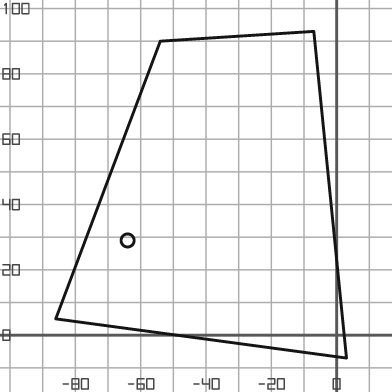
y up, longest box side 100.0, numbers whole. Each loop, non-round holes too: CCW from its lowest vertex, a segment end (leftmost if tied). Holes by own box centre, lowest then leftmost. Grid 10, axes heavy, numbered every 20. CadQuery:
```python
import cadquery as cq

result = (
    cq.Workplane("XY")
    .moveTo(3.0, -7.0)
    .lineTo(-7.0, 93.0)
    .lineTo(-54.0, 90.0)
    .lineTo(-86.0, 5.0)
    .close()
    .moveTo(-64.0, 29.0)
    .circle(2.0)
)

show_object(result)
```